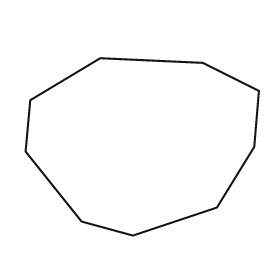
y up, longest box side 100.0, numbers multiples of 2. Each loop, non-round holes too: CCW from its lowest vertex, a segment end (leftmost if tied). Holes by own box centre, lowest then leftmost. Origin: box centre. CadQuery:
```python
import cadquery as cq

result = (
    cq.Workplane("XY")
    .moveTo(-4.0, -38.0)
    .lineTo(32.0, -26.0)
    .lineTo(48.0, 0.0)
    .lineTo(50.0, 24.0)
    .lineTo(26.0, 36.0)
    .lineTo(-18.0, 38.0)
    .lineTo(-48.0, 20.0)
    .lineTo(-50.0, -2.0)
    .lineTo(-26.0, -32.0)
    .close()
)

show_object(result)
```